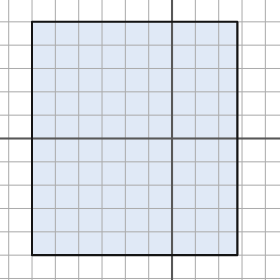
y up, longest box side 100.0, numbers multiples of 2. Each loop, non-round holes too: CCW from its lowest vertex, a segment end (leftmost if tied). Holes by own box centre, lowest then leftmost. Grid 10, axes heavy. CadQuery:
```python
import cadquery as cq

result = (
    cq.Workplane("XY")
    .moveTo(-60.0, -50.0)
    .lineTo(28.0, -50.0)
    .lineTo(28.0, 50.0)
    .lineTo(-60.0, 50.0)
    .close()
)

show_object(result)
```